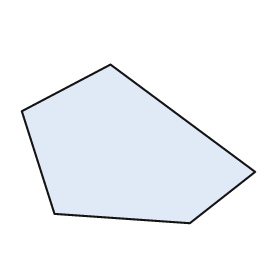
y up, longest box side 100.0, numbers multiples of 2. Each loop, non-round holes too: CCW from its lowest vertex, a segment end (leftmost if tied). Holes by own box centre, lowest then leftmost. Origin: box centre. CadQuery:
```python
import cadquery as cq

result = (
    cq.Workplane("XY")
    .moveTo(22.0, -34.0)
    .lineTo(50.0, -12.0)
    .lineTo(-12.0, 34.0)
    .lineTo(-50.0, 14.0)
    .lineTo(-36.0, -30.0)
    .close()
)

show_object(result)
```